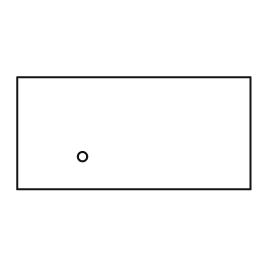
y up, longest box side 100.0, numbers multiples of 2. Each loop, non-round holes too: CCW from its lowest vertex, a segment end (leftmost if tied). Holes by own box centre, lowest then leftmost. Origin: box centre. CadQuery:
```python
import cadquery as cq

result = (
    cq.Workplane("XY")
    .moveTo(-50.0, -24.0)
    .lineTo(50.0, -24.0)
    .lineTo(50.0, 24.0)
    .lineTo(-50.0, 24.0)
    .close()
    .moveTo(-22.0, -10.0)
    .circle(2.0)
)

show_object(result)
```